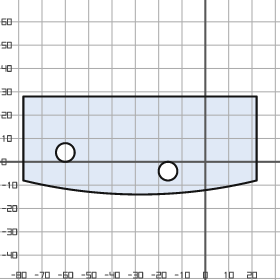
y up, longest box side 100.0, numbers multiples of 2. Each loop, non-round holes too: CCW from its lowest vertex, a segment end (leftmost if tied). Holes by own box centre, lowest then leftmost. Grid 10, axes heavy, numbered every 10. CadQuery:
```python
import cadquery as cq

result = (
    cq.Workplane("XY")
    .moveTo(-78.0, -8.0)
    .threePointArc((-28.0, -14.0), (22.0, -8.0))
    .lineTo(22.0, 28.0)
    .lineTo(-78.0, 28.0)
    .close()
    .moveTo(-16.0, -4.0)
    .circle(4.0)
    .moveTo(-60.0, 4.0)
    .circle(4.0)
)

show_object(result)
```